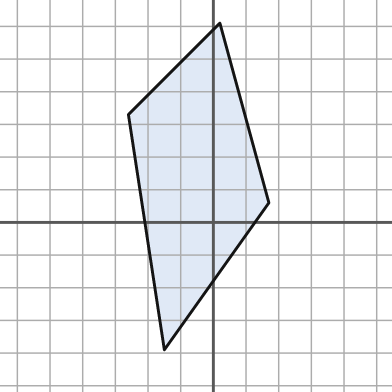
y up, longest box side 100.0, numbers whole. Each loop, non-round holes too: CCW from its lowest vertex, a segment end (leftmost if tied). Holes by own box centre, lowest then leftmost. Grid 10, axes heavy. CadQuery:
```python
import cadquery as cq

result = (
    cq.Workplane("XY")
    .moveTo(-15.0, -39.0)
    .lineTo(17.0, 6.0)
    .lineTo(2.0, 61.0)
    .lineTo(-26.0, 33.0)
    .close()
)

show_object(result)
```